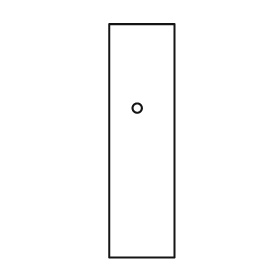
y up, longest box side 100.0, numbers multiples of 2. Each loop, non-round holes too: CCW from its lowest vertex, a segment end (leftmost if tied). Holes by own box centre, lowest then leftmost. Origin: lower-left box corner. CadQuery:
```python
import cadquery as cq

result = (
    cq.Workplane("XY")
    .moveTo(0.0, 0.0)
    .lineTo(28.0, 0.0)
    .lineTo(28.0, 100.0)
    .lineTo(0.0, 100.0)
    .close()
    .moveTo(12.0, 64.0)
    .circle(2.0)
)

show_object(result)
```